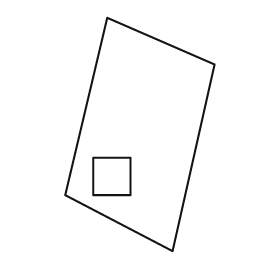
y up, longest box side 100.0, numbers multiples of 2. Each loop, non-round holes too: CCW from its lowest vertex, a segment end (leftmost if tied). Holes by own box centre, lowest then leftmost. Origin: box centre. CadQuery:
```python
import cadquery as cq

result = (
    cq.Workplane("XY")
    .moveTo(14.0, -50.0)
    .lineTo(32.0, 30.0)
    .lineTo(-14.0, 50.0)
    .lineTo(-32.0, -26.0)
    .close()
    .moveTo(-20.0, -26.0)
    .lineTo(-4.0, -26.0)
    .lineTo(-4.0, -10.0)
    .lineTo(-20.0, -10.0)
    .close()
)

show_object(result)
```